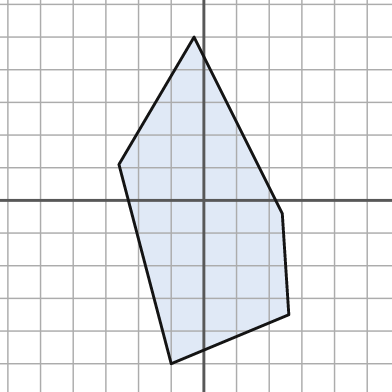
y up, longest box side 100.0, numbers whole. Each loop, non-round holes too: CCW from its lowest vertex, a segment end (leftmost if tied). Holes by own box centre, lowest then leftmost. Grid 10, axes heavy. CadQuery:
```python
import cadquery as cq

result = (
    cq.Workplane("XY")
    .moveTo(-10.0, -50.0)
    .lineTo(26.0, -35.0)
    .lineTo(24.0, -4.0)
    .lineTo(-3.0, 50.0)
    .lineTo(-26.0, 11.0)
    .close()
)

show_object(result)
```